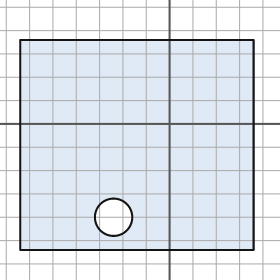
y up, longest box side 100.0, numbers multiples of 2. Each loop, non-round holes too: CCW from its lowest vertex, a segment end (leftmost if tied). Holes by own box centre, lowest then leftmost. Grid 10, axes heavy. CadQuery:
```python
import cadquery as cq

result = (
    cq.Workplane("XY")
    .moveTo(-64.0, -54.0)
    .lineTo(36.0, -54.0)
    .lineTo(36.0, 36.0)
    .lineTo(-64.0, 36.0)
    .close()
    .moveTo(-24.0, -40.0)
    .circle(8.0)
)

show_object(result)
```